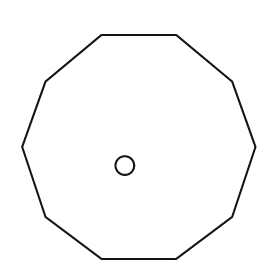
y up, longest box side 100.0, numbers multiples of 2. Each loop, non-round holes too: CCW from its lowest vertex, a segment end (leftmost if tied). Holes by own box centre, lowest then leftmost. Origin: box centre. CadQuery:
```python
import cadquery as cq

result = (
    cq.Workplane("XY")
    .moveTo(-16.0, -48.0)
    .lineTo(16.0, -48.0)
    .lineTo(40.0, -30.0)
    .lineTo(50.0, 0.0)
    .lineTo(40.0, 28.0)
    .lineTo(16.0, 48.0)
    .lineTo(-16.0, 48.0)
    .lineTo(-40.0, 28.0)
    .lineTo(-50.0, 0.0)
    .lineTo(-40.0, -30.0)
    .close()
    .moveTo(-6.0, -8.0)
    .circle(4.0)
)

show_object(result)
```